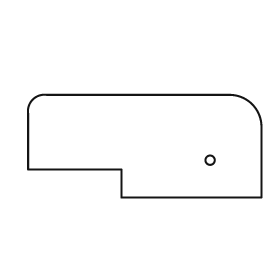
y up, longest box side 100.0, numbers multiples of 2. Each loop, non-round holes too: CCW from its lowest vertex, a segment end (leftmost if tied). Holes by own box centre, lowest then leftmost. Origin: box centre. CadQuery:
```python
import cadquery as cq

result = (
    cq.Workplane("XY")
    .moveTo(-10.0, -22.0)
    .lineTo(50.0, -22.0)
    .lineTo(50.0, 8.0)
    .threePointArc((46.0, 18.0), (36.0, 22.0))
    .lineTo(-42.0, 22.0)
    .threePointArc((-48.0, 20.0), (-50.0, 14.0))
    .lineTo(-50.0, -10.0)
    .lineTo(-10.0, -10.0)
    .close()
    .moveTo(28.0, -6.0)
    .circle(2.0)
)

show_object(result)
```